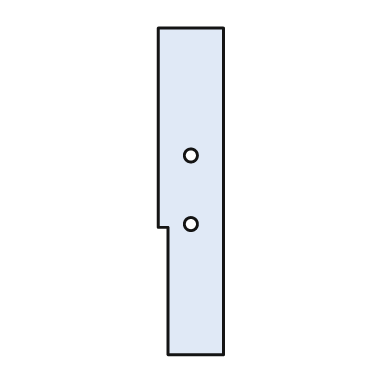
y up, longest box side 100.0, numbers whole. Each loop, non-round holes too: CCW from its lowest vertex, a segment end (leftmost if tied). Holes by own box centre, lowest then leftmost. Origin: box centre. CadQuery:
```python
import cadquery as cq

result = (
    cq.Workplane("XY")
    .moveTo(-7.0, -50.0)
    .lineTo(10.0, -50.0)
    .lineTo(10.0, 50.0)
    .lineTo(-10.0, 50.0)
    .lineTo(-10.0, -11.0)
    .lineTo(-7.0, -11.0)
    .close()
    .moveTo(0.0, -10.0)
    .circle(2.0)
    .moveTo(0.0, 11.0)
    .circle(2.0)
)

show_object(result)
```